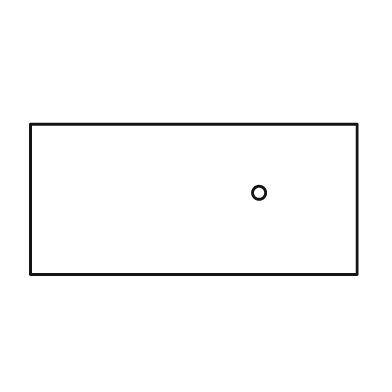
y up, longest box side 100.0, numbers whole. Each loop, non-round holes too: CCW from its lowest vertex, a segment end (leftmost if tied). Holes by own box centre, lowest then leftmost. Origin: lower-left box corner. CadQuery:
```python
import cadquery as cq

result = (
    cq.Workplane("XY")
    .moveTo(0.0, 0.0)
    .lineTo(100.0, 0.0)
    .lineTo(100.0, 46.0)
    .lineTo(0.0, 46.0)
    .close()
    .moveTo(70.0, 25.0)
    .circle(2.0)
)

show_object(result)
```